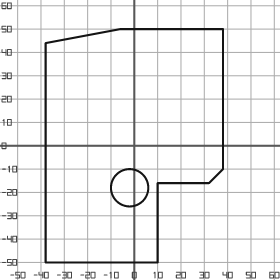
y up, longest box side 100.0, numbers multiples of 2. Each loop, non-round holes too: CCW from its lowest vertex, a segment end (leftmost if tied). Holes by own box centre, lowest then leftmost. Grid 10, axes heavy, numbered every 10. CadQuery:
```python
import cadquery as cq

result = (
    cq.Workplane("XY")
    .moveTo(-38.0, -50.0)
    .lineTo(10.0, -50.0)
    .lineTo(10.0, -16.0)
    .lineTo(32.0, -16.0)
    .lineTo(38.0, -10.0)
    .lineTo(38.0, 50.0)
    .lineTo(-6.0, 50.0)
    .lineTo(-38.0, 44.0)
    .close()
    .moveTo(-2.0, -18.0)
    .circle(8.0)
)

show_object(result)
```